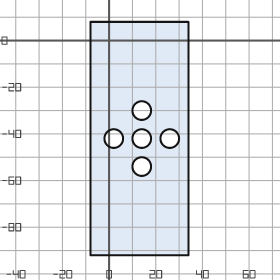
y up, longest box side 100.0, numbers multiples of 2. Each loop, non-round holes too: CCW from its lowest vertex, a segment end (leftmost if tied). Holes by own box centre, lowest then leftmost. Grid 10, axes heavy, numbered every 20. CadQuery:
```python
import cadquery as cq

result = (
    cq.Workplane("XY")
    .moveTo(-8.0, -92.0)
    .lineTo(34.0, -92.0)
    .lineTo(34.0, 8.0)
    .lineTo(-8.0, 8.0)
    .close()
    .moveTo(14.0, -54.0)
    .circle(4.0)
    .moveTo(2.0, -42.0)
    .circle(4.0)
    .moveTo(14.0, -42.0)
    .circle(4.0)
    .moveTo(26.0, -42.0)
    .circle(4.0)
    .moveTo(14.0, -30.0)
    .circle(4.0)
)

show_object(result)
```